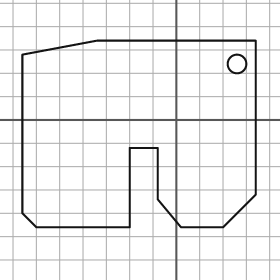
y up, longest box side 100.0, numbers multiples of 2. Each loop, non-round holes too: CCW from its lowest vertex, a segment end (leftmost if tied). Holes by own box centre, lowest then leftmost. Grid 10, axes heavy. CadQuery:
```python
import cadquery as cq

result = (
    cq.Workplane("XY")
    .moveTo(-60.0, -46.0)
    .lineTo(-20.0, -46.0)
    .lineTo(-20.0, -12.0)
    .lineTo(-8.0, -12.0)
    .lineTo(-8.0, -34.0)
    .lineTo(2.0, -46.0)
    .lineTo(20.0, -46.0)
    .lineTo(34.0, -32.0)
    .lineTo(34.0, 34.0)
    .lineTo(-34.0, 34.0)
    .lineTo(-66.0, 28.0)
    .lineTo(-66.0, -40.0)
    .close()
    .moveTo(26.0, 24.0)
    .circle(4.0)
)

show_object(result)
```